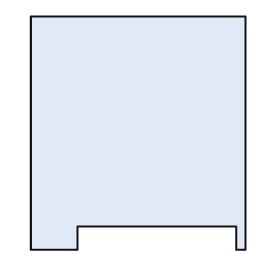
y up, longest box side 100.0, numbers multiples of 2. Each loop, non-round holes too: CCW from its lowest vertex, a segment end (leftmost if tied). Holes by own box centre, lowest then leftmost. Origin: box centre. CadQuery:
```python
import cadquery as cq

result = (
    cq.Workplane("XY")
    .moveTo(-46.0, -50.0)
    .lineTo(-26.0, -50.0)
    .lineTo(-26.0, -40.0)
    .lineTo(42.0, -40.0)
    .lineTo(42.0, -50.0)
    .lineTo(46.0, -50.0)
    .lineTo(46.0, 50.0)
    .lineTo(-46.0, 50.0)
    .close()
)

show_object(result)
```